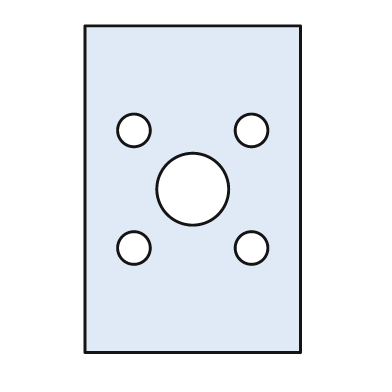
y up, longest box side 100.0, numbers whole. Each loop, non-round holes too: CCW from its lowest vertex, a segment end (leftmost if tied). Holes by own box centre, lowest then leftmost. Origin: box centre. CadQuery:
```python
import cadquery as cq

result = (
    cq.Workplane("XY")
    .moveTo(-33.0, -50.0)
    .lineTo(33.0, -50.0)
    .lineTo(33.0, 50.0)
    .lineTo(-33.0, 50.0)
    .close()
    .moveTo(-18.0, -18.0)
    .circle(5.0)
    .moveTo(18.0, -18.0)
    .circle(5.0)
    .moveTo(0.0, 0.0)
    .circle(11.0)
    .moveTo(-18.0, 18.0)
    .circle(5.0)
    .moveTo(18.0, 18.0)
    .circle(5.0)
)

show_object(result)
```